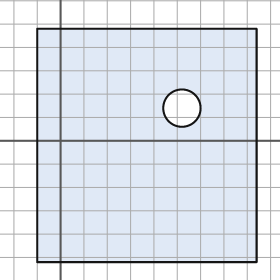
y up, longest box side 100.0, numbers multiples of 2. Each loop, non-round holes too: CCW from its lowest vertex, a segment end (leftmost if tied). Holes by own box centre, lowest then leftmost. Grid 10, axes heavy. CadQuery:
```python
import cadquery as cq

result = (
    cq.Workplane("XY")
    .moveTo(-10.0, -52.0)
    .lineTo(84.0, -52.0)
    .lineTo(84.0, 48.0)
    .lineTo(-10.0, 48.0)
    .close()
    .moveTo(52.0, 14.0)
    .circle(8.0)
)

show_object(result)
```